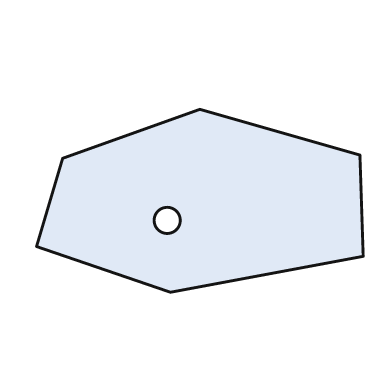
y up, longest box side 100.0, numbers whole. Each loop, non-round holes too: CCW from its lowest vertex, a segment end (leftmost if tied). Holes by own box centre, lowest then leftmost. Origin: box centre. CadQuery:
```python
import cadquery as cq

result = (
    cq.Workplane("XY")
    .moveTo(-9.0, -28.0)
    .lineTo(50.0, -17.0)
    .lineTo(49.0, 14.0)
    .lineTo(0.0, 28.0)
    .lineTo(-42.0, 13.0)
    .lineTo(-50.0, -14.0)
    .close()
    .moveTo(-10.0, -6.0)
    .circle(4.0)
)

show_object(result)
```